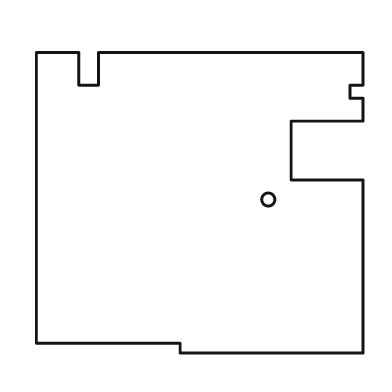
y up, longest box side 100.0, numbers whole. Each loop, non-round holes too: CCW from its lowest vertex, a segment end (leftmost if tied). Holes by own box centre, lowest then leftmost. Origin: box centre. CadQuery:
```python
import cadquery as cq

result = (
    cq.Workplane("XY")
    .moveTo(-6.0, -46.0)
    .lineTo(50.0, -46.0)
    .lineTo(50.0, 7.0)
    .lineTo(28.0, 7.0)
    .lineTo(28.0, 25.0)
    .lineTo(50.0, 25.0)
    .lineTo(50.0, 32.0)
    .lineTo(46.0, 32.0)
    .lineTo(46.0, 36.0)
    .lineTo(50.0, 36.0)
    .lineTo(50.0, 46.0)
    .lineTo(-31.0, 46.0)
    .lineTo(-31.0, 36.0)
    .lineTo(-37.0, 36.0)
    .lineTo(-37.0, 46.0)
    .lineTo(-50.0, 46.0)
    .lineTo(-50.0, -43.0)
    .lineTo(-6.0, -43.0)
    .close()
    .moveTo(21.0, 1.0)
    .circle(2.0)
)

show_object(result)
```